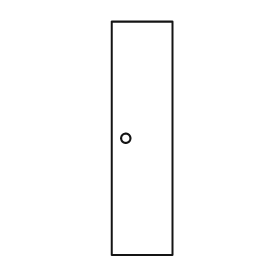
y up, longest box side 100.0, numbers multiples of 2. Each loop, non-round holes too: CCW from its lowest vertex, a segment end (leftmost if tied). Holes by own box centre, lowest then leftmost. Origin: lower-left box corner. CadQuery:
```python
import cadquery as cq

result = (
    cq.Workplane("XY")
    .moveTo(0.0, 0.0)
    .lineTo(26.0, 0.0)
    .lineTo(26.0, 100.0)
    .lineTo(0.0, 100.0)
    .close()
    .moveTo(6.0, 50.0)
    .circle(2.0)
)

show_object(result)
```